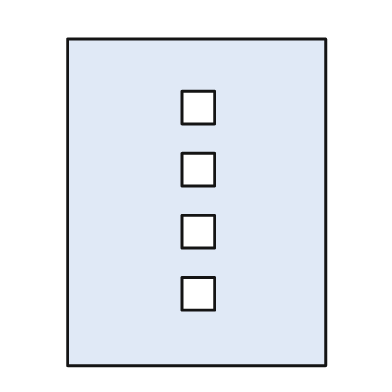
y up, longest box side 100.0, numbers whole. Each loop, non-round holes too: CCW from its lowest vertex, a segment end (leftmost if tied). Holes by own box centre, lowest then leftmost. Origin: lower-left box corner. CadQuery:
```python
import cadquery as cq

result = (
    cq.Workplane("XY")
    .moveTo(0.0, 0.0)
    .lineTo(79.0, 0.0)
    .lineTo(79.0, 100.0)
    .lineTo(0.0, 100.0)
    .close()
    .moveTo(35.0, 17.0)
    .lineTo(45.0, 17.0)
    .lineTo(45.0, 27.0)
    .lineTo(35.0, 27.0)
    .close()
    .moveTo(35.0, 36.0)
    .lineTo(45.0, 36.0)
    .lineTo(45.0, 46.0)
    .lineTo(35.0, 46.0)
    .close()
    .moveTo(35.0, 55.0)
    .lineTo(45.0, 55.0)
    .lineTo(45.0, 65.0)
    .lineTo(35.0, 65.0)
    .close()
    .moveTo(35.0, 74.0)
    .lineTo(45.0, 74.0)
    .lineTo(45.0, 84.0)
    .lineTo(35.0, 84.0)
    .close()
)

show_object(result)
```